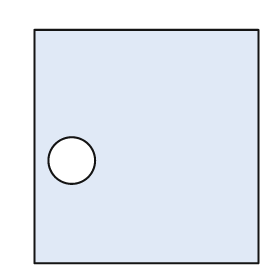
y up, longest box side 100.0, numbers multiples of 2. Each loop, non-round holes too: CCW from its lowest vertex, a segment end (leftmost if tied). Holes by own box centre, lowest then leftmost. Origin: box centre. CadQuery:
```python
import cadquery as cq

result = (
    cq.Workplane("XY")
    .moveTo(-48.0, -50.0)
    .lineTo(48.0, -50.0)
    .lineTo(48.0, 50.0)
    .lineTo(-48.0, 50.0)
    .close()
    .moveTo(-32.0, -6.0)
    .circle(10.0)
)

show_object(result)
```